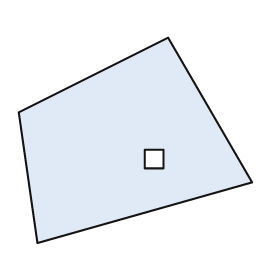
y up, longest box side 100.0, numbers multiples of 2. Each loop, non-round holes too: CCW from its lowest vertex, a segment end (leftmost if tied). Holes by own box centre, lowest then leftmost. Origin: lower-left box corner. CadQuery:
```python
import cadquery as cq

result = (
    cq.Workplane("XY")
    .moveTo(8.0, 0.0)
    .lineTo(100.0, 26.0)
    .lineTo(64.0, 88.0)
    .lineTo(0.0, 56.0)
    .close()
    .moveTo(54.0, 32.0)
    .lineTo(62.0, 32.0)
    .lineTo(62.0, 40.0)
    .lineTo(54.0, 40.0)
    .close()
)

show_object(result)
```